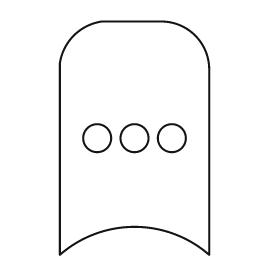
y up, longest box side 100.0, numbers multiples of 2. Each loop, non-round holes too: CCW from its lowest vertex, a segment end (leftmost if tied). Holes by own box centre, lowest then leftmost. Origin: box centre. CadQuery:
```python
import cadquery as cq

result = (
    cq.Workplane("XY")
    .moveTo(-32.0, -50.0)
    .threePointArc((0.0, -38.0), (32.0, -50.0))
    .lineTo(32.0, 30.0)
    .threePointArc((26.0, 44.0), (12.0, 50.0))
    .lineTo(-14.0, 50.0)
    .threePointArc((-26.0, 44.0), (-32.0, 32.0))
    .close()
    .moveTo(-16.0, 0.0)
    .circle(6.0)
    .moveTo(0.0, 0.0)
    .circle(6.0)
    .moveTo(16.0, 0.0)
    .circle(6.0)
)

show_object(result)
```